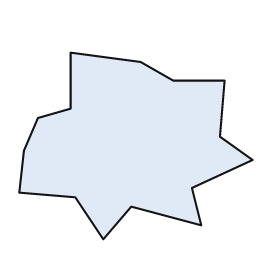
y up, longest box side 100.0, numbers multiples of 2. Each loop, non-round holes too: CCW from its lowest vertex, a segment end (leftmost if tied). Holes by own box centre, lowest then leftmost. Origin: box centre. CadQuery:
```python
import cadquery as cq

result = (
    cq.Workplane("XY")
    .moveTo(-14.0, -40.0)
    .lineTo(-2.0, -26.0)
    .lineTo(28.0, -34.0)
    .lineTo(24.0, -18.0)
    .lineTo(50.0, -6.0)
    .lineTo(36.0, 4.0)
    .lineTo(38.0, 28.0)
    .lineTo(16.0, 28.0)
    .lineTo(2.0, 36.0)
    .lineTo(-28.0, 40.0)
    .lineTo(-28.0, 16.0)
    .lineTo(-42.0, 12.0)
    .lineTo(-48.0, -2.0)
    .lineTo(-50.0, -20.0)
    .lineTo(-26.0, -22.0)
    .close()
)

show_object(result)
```